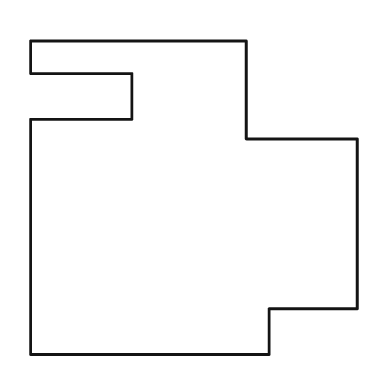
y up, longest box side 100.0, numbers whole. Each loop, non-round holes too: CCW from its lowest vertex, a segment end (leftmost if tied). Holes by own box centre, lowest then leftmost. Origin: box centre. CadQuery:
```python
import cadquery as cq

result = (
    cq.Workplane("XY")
    .moveTo(-50.0, -48.0)
    .lineTo(23.0, -48.0)
    .lineTo(23.0, -34.0)
    .lineTo(50.0, -34.0)
    .lineTo(50.0, 18.0)
    .lineTo(16.0, 18.0)
    .lineTo(16.0, 48.0)
    .lineTo(-50.0, 48.0)
    .lineTo(-50.0, 38.0)
    .lineTo(-19.0, 38.0)
    .lineTo(-19.0, 24.0)
    .lineTo(-50.0, 24.0)
    .close()
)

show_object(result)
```